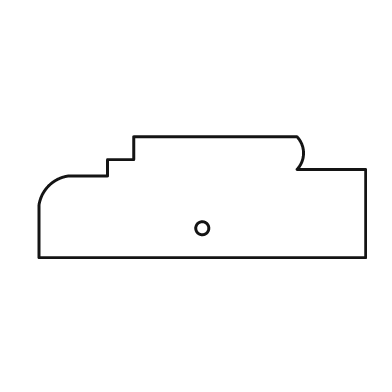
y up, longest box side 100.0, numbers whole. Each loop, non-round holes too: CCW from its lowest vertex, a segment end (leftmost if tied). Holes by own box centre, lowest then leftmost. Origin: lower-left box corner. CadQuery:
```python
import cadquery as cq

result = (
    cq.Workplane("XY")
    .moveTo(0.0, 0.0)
    .lineTo(100.0, 0.0)
    .lineTo(100.0, 27.0)
    .lineTo(79.0, 27.0)
    .threePointArc((81.0, 32.0), (79.0, 37.0))
    .lineTo(29.0, 37.0)
    .lineTo(29.0, 30.0)
    .lineTo(21.0, 30.0)
    .lineTo(21.0, 25.0)
    .lineTo(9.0, 25.0)
    .threePointArc((3.0, 22.0), (0.0, 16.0))
    .close()
    .moveTo(50.0, 9.0)
    .circle(2.0)
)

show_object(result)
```